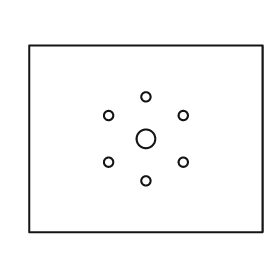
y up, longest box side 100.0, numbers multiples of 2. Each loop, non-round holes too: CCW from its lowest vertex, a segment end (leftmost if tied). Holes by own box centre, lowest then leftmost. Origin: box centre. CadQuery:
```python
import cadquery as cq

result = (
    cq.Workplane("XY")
    .moveTo(-50.0, -40.0)
    .lineTo(50.0, -40.0)
    .lineTo(50.0, 40.0)
    .lineTo(-50.0, 40.0)
    .close()
    .moveTo(0.0, -18.0)
    .circle(2.0)
    .moveTo(-16.0, -10.0)
    .circle(2.0)
    .moveTo(16.0, -10.0)
    .circle(2.0)
    .moveTo(0.0, 0.0)
    .circle(4.0)
    .moveTo(-16.0, 10.0)
    .circle(2.0)
    .moveTo(16.0, 10.0)
    .circle(2.0)
    .moveTo(0.0, 18.0)
    .circle(2.0)
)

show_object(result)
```